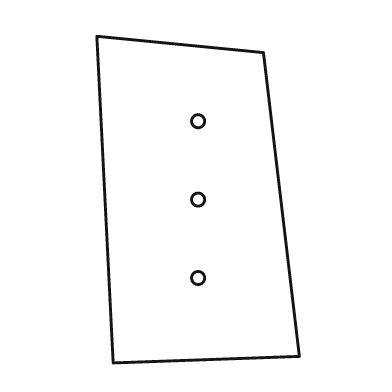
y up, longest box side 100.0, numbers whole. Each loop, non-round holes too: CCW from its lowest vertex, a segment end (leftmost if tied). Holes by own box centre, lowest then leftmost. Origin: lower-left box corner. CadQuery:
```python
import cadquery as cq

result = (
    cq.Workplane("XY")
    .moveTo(5.0, 0.0)
    .lineTo(62.0, 2.0)
    .lineTo(51.0, 95.0)
    .lineTo(0.0, 100.0)
    .close()
    .moveTo(31.0, 26.0)
    .circle(2.0)
    .moveTo(31.0, 50.0)
    .circle(2.0)
    .moveTo(31.0, 74.0)
    .circle(2.0)
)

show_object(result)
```